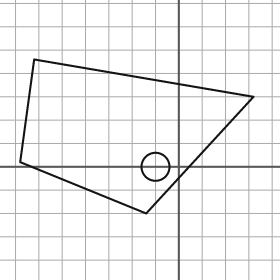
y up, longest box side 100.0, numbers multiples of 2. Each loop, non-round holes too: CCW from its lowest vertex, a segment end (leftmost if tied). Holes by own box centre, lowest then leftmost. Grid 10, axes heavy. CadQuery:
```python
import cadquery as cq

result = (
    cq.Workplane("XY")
    .moveTo(-14.0, -20.0)
    .lineTo(32.0, 30.0)
    .lineTo(-62.0, 46.0)
    .lineTo(-68.0, 2.0)
    .close()
    .moveTo(-10.0, 0.0)
    .circle(6.0)
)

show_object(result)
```